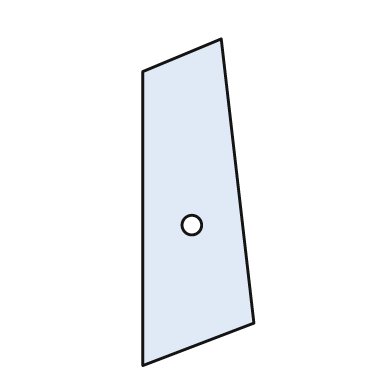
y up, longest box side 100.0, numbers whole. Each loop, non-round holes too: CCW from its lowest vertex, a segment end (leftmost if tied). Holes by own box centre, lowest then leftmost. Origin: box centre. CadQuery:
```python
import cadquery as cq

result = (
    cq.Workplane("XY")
    .moveTo(-17.0, -50.0)
    .lineTo(17.0, -37.0)
    .lineTo(7.0, 50.0)
    .lineTo(-17.0, 40.0)
    .close()
    .moveTo(-2.0, -7.0)
    .circle(3.0)
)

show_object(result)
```